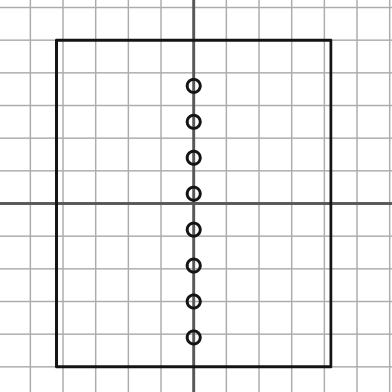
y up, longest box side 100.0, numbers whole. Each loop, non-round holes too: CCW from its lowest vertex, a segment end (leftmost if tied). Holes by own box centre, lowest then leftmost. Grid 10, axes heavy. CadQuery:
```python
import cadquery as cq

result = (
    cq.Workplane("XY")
    .moveTo(-42.0, -50.0)
    .lineTo(42.0, -50.0)
    .lineTo(42.0, 50.0)
    .lineTo(-42.0, 50.0)
    .close()
    .moveTo(0.0, -41.0)
    .circle(2.0)
    .moveTo(0.0, -30.0)
    .circle(2.0)
    .moveTo(0.0, -19.0)
    .circle(2.0)
    .moveTo(0.0, -8.0)
    .circle(2.0)
    .moveTo(0.0, 3.0)
    .circle(2.0)
    .moveTo(0.0, 14.0)
    .circle(2.0)
    .moveTo(0.0, 25.0)
    .circle(2.0)
    .moveTo(0.0, 36.0)
    .circle(2.0)
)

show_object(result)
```